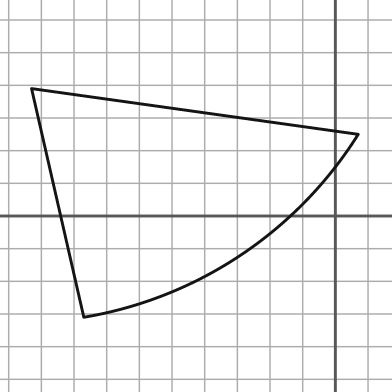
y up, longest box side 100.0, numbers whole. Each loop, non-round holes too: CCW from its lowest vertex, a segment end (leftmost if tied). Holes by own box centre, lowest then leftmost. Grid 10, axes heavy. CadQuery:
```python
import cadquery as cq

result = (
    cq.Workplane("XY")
    .moveTo(-77.0, -31.0)
    .threePointArc((-29.0, -12.0), (7.0, 25.0))
    .lineTo(-93.0, 39.0)
    .close()
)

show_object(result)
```